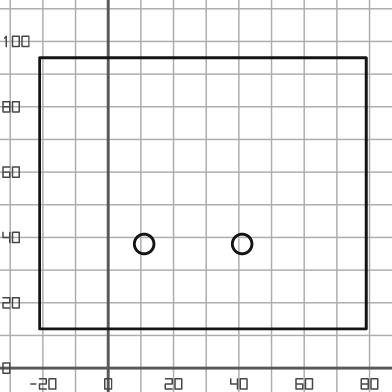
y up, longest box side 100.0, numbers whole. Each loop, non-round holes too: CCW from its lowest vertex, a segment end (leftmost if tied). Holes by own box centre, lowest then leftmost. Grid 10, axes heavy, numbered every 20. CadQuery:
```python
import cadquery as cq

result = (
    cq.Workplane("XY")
    .moveTo(-21.0, 12.0)
    .lineTo(79.0, 12.0)
    .lineTo(79.0, 95.0)
    .lineTo(-21.0, 95.0)
    .close()
    .moveTo(11.0, 38.0)
    .circle(3.0)
    .moveTo(41.0, 38.0)
    .circle(3.0)
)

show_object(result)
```